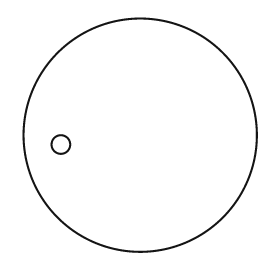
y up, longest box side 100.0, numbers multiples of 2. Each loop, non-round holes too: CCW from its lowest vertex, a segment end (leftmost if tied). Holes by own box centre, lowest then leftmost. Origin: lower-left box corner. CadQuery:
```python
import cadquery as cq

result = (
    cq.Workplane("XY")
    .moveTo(50.0, 50.0)
    .circle(50.0)
    .moveTo(16.0, 46.0)
    .circle(4.0)
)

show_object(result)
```